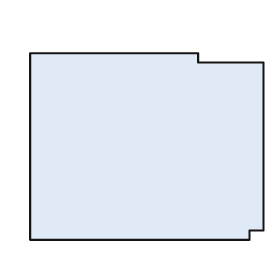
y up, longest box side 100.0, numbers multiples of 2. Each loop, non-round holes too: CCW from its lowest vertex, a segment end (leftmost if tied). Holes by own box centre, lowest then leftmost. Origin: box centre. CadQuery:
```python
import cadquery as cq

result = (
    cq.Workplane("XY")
    .moveTo(-50.0, -40.0)
    .lineTo(44.0, -40.0)
    .lineTo(44.0, -36.0)
    .lineTo(50.0, -36.0)
    .lineTo(50.0, 36.0)
    .lineTo(22.0, 36.0)
    .lineTo(22.0, 40.0)
    .lineTo(-50.0, 40.0)
    .close()
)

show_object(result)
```